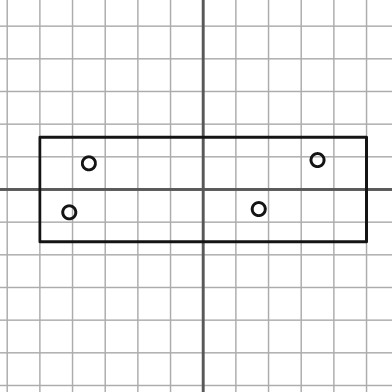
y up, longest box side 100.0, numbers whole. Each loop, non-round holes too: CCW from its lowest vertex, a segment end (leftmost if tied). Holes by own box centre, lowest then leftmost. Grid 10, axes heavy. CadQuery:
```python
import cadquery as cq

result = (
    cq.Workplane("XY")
    .moveTo(-50.0, -16.0)
    .lineTo(50.0, -16.0)
    .lineTo(50.0, 16.0)
    .lineTo(-50.0, 16.0)
    .close()
    .moveTo(-41.0, -7.0)
    .circle(2.0)
    .moveTo(17.0, -6.0)
    .circle(2.0)
    .moveTo(-35.0, 8.0)
    .circle(2.0)
    .moveTo(35.0, 9.0)
    .circle(2.0)
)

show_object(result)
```